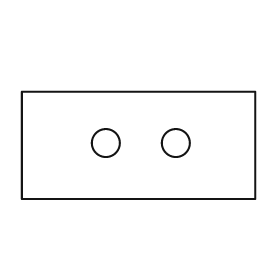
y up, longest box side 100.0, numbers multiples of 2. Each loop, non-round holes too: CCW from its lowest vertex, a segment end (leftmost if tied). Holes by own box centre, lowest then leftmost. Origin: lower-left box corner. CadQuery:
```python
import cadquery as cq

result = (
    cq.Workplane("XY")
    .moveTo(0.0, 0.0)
    .lineTo(100.0, 0.0)
    .lineTo(100.0, 46.0)
    .lineTo(0.0, 46.0)
    .close()
    .moveTo(36.0, 24.0)
    .circle(6.0)
    .moveTo(66.0, 24.0)
    .circle(6.0)
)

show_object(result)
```